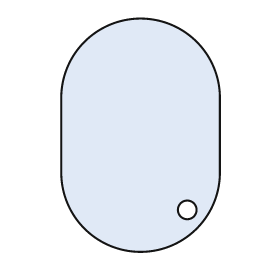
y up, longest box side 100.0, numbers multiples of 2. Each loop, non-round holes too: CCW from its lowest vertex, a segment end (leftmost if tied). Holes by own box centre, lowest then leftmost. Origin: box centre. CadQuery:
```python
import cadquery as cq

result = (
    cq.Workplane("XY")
    .moveTo(-34.0, -16.0)
    .threePointArc((0.0, -50.0), (34.0, -16.0))
    .lineTo(34.0, 16.0)
    .threePointArc((0.0, 50.0), (-34.0, 16.0))
    .close()
    .moveTo(20.0, -32.0)
    .circle(4.0)
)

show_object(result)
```